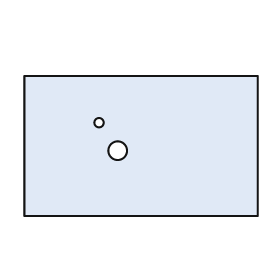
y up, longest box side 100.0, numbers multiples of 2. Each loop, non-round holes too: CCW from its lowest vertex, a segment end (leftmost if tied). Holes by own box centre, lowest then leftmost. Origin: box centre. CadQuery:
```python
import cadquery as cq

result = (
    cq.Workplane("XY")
    .moveTo(-50.0, -30.0)
    .lineTo(50.0, -30.0)
    .lineTo(50.0, 30.0)
    .lineTo(-50.0, 30.0)
    .close()
    .moveTo(-10.0, -2.0)
    .circle(4.0)
    .moveTo(-18.0, 10.0)
    .circle(2.0)
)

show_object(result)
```